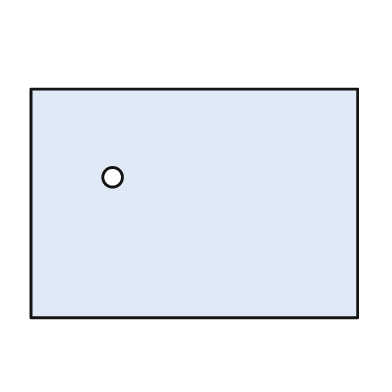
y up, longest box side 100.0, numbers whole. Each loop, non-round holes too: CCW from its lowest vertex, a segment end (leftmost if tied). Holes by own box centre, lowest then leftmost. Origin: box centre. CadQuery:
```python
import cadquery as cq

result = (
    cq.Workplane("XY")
    .moveTo(-50.0, -35.0)
    .lineTo(50.0, -35.0)
    .lineTo(50.0, 35.0)
    .lineTo(-50.0, 35.0)
    .close()
    .moveTo(-25.0, 8.0)
    .circle(3.0)
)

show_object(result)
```